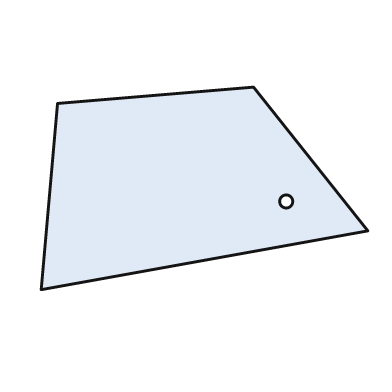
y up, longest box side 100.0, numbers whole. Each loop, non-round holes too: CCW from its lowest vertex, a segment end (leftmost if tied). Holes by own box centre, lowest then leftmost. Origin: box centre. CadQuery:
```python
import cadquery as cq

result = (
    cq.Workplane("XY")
    .moveTo(-50.0, -31.0)
    .lineTo(50.0, -13.0)
    .lineTo(15.0, 31.0)
    .lineTo(-45.0, 26.0)
    .close()
    .moveTo(25.0, -4.0)
    .circle(2.0)
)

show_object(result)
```